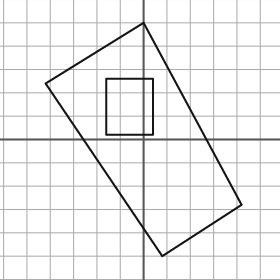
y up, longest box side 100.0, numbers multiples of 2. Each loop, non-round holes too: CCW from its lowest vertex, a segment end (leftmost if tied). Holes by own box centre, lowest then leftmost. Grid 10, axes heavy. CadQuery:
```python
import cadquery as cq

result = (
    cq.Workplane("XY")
    .moveTo(8.0, -50.0)
    .lineTo(42.0, -28.0)
    .lineTo(0.0, 50.0)
    .lineTo(-42.0, 24.0)
    .close()
    .moveTo(-16.0, 2.0)
    .lineTo(4.0, 2.0)
    .lineTo(4.0, 26.0)
    .lineTo(-16.0, 26.0)
    .close()
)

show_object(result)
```